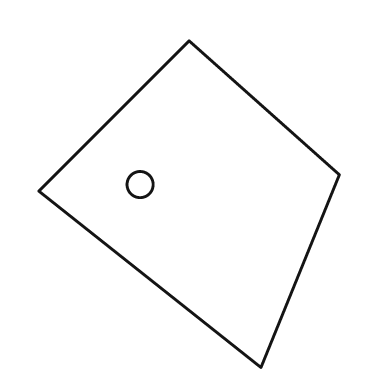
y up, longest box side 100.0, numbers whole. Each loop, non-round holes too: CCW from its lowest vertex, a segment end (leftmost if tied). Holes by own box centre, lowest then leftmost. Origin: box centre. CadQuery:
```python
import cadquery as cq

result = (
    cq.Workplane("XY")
    .moveTo(22.0, -50.0)
    .lineTo(46.0, 9.0)
    .lineTo(0.0, 50.0)
    .lineTo(-46.0, 4.0)
    .close()
    .moveTo(-15.0, 6.0)
    .circle(4.0)
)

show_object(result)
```